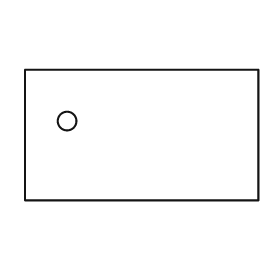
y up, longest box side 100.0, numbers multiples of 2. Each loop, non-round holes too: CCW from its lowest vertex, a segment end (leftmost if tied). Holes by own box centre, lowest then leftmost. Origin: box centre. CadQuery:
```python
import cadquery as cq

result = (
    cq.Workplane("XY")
    .moveTo(-50.0, -28.0)
    .lineTo(50.0, -28.0)
    .lineTo(50.0, 28.0)
    .lineTo(-50.0, 28.0)
    .close()
    .moveTo(-32.0, 6.0)
    .circle(4.0)
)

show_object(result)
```